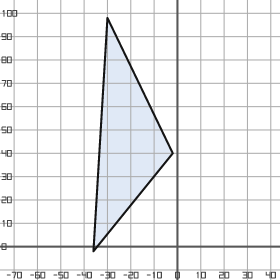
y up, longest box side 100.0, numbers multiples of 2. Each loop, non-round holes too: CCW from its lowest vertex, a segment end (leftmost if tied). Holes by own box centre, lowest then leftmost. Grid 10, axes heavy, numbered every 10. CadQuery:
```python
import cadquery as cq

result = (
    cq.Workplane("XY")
    .moveTo(-36.0, -2.0)
    .lineTo(-2.0, 40.0)
    .lineTo(-30.0, 98.0)
    .close()
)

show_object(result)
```